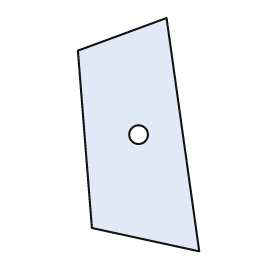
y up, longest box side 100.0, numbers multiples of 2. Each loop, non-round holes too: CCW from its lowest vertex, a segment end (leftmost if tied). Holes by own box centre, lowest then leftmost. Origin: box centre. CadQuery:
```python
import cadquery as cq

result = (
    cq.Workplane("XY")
    .moveTo(26.0, -50.0)
    .lineTo(12.0, 50.0)
    .lineTo(-26.0, 36.0)
    .lineTo(-20.0, -40.0)
    .close()
    .moveTo(0.0, 0.0)
    .circle(4.0)
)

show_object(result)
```